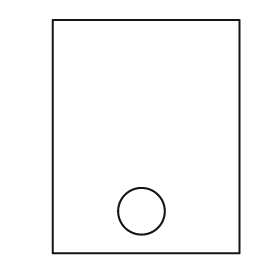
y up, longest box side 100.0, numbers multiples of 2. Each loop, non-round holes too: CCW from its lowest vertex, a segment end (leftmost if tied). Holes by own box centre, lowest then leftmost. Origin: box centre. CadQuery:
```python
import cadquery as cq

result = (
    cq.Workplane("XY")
    .moveTo(-40.0, -50.0)
    .lineTo(40.0, -50.0)
    .lineTo(40.0, 50.0)
    .lineTo(-40.0, 50.0)
    .close()
    .moveTo(-2.0, -32.0)
    .circle(10.0)
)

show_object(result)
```